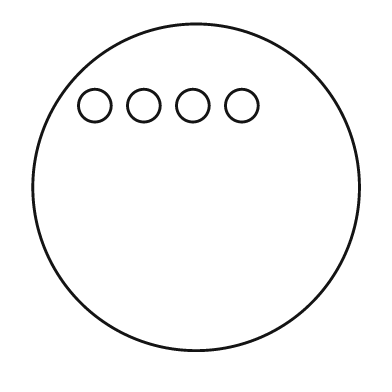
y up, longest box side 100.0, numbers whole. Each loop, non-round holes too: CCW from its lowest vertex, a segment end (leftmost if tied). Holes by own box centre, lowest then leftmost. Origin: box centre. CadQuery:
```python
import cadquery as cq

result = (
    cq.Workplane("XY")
    .moveTo(0.0, 0.0)
    .circle(50.0)
    .moveTo(-31.0, 25.0)
    .circle(5.0)
    .moveTo(-16.0, 25.0)
    .circle(5.0)
    .moveTo(-1.0, 25.0)
    .circle(5.0)
    .moveTo(14.0, 25.0)
    .circle(5.0)
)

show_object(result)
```